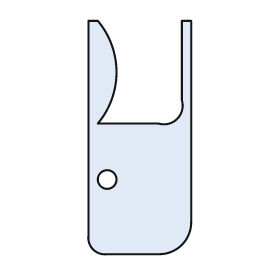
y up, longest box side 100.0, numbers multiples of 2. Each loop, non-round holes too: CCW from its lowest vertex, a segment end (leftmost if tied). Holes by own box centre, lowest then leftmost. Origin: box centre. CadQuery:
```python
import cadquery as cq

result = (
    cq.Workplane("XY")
    .moveTo(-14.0, -50.0)
    .lineTo(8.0, -50.0)
    .threePointArc((18.0, -46.0), (22.0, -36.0))
    .lineTo(22.0, 50.0)
    .lineTo(18.0, 50.0)
    .lineTo(18.0, 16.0)
    .threePointArc((16.0, 8.0), (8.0, 6.0))
    .lineTo(-18.0, 6.0)
    .threePointArc((-10.0, 28.0), (-18.0, 50.0))
    .lineTo(-22.0, 50.0)
    .lineTo(-22.0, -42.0)
    .threePointArc((-20.0, -48.0), (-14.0, -50.0))
    .close()
    .moveTo(-14.0, -18.0)
    .circle(4.0)
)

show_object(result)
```